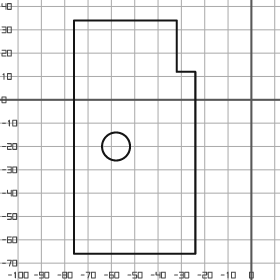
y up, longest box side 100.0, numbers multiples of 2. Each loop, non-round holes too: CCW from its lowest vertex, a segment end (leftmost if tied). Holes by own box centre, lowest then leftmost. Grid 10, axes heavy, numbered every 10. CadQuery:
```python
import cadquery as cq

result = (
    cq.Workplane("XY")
    .moveTo(-76.0, -66.0)
    .lineTo(-24.0, -66.0)
    .lineTo(-24.0, 12.0)
    .lineTo(-32.0, 12.0)
    .lineTo(-32.0, 34.0)
    .lineTo(-76.0, 34.0)
    .close()
    .moveTo(-58.0, -20.0)
    .circle(6.0)
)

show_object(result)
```